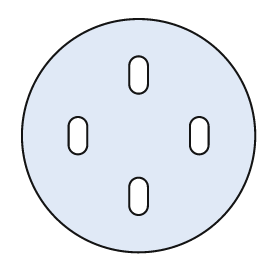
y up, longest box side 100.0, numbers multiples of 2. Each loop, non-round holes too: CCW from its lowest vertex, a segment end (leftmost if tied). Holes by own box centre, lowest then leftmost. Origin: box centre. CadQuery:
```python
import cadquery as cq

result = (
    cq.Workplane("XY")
    .moveTo(0.0, 0.0)
    .circle(50.0)
    .moveTo(-4.0, -30.0)
    .threePointArc((0.0, -34.0), (4.0, -30.0))
    .lineTo(4.0, -22.0)
    .threePointArc((0.0, -18.0), (-4.0, -22.0))
    .close()
    .moveTo(-30.0, -4.0)
    .threePointArc((-26.0, -8.0), (-22.0, -4.0))
    .lineTo(-22.0, 4.0)
    .threePointArc((-26.0, 8.0), (-30.0, 4.0))
    .close()
    .moveTo(22.0, -4.0)
    .threePointArc((26.0, -8.0), (30.0, -4.0))
    .lineTo(30.0, 4.0)
    .threePointArc((26.0, 8.0), (22.0, 4.0))
    .close()
    .moveTo(-4.0, 22.0)
    .threePointArc((0.0, 18.0), (4.0, 22.0))
    .lineTo(4.0, 30.0)
    .threePointArc((0.0, 34.0), (-4.0, 30.0))
    .close()
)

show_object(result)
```